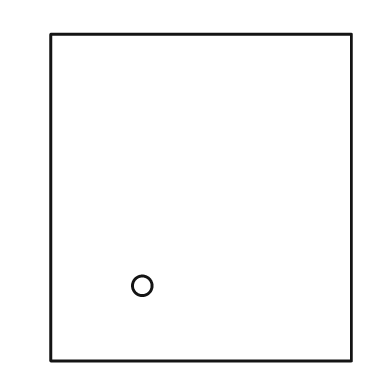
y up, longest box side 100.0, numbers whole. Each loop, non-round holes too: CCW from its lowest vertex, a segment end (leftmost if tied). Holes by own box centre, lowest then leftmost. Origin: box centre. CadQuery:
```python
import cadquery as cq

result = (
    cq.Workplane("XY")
    .moveTo(-46.0, -50.0)
    .lineTo(46.0, -50.0)
    .lineTo(46.0, 50.0)
    .lineTo(-46.0, 50.0)
    .close()
    .moveTo(-18.0, -27.0)
    .circle(3.0)
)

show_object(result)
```